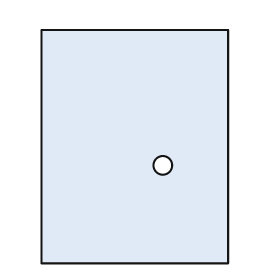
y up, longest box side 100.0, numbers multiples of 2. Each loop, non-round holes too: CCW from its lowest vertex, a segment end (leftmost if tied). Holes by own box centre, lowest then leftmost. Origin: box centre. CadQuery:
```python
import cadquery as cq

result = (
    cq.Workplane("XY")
    .moveTo(-40.0, -50.0)
    .lineTo(40.0, -50.0)
    .lineTo(40.0, 50.0)
    .lineTo(-40.0, 50.0)
    .close()
    .moveTo(12.0, -8.0)
    .circle(4.0)
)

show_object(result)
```